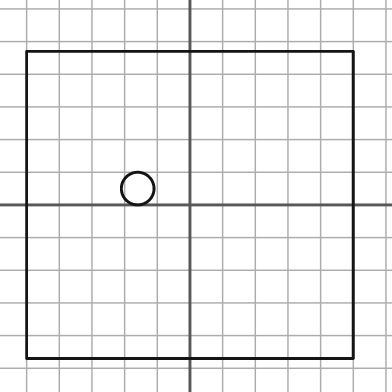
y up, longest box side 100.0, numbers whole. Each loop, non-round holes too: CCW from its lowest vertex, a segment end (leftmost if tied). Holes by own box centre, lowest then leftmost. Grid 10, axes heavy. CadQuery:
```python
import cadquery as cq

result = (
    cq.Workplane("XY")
    .moveTo(-50.0, -47.0)
    .lineTo(50.0, -47.0)
    .lineTo(50.0, 47.0)
    .lineTo(-50.0, 47.0)
    .close()
    .moveTo(-16.0, 5.0)
    .circle(5.0)
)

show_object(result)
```